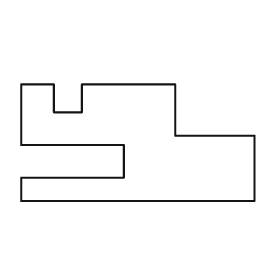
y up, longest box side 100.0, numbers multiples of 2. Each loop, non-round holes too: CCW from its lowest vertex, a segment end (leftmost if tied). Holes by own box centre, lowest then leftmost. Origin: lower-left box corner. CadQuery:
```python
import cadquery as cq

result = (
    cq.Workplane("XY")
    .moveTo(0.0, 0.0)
    .lineTo(100.0, 0.0)
    .lineTo(100.0, 28.0)
    .lineTo(66.0, 28.0)
    .lineTo(66.0, 50.0)
    .lineTo(26.0, 50.0)
    .lineTo(26.0, 38.0)
    .lineTo(14.0, 38.0)
    .lineTo(14.0, 50.0)
    .lineTo(0.0, 50.0)
    .lineTo(0.0, 24.0)
    .lineTo(44.0, 24.0)
    .lineTo(44.0, 10.0)
    .lineTo(0.0, 10.0)
    .close()
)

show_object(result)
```